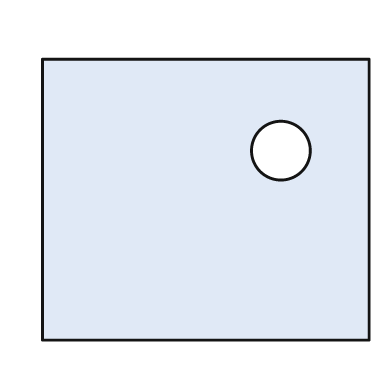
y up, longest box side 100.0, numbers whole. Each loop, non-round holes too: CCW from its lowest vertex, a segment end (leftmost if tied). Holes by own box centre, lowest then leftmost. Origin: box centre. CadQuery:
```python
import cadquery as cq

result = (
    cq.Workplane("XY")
    .moveTo(-50.0, -43.0)
    .lineTo(50.0, -43.0)
    .lineTo(50.0, 43.0)
    .lineTo(-50.0, 43.0)
    .close()
    .moveTo(23.0, 15.0)
    .circle(9.0)
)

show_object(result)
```